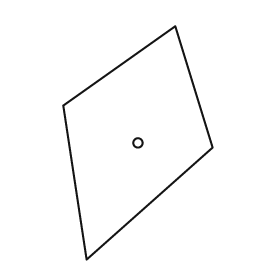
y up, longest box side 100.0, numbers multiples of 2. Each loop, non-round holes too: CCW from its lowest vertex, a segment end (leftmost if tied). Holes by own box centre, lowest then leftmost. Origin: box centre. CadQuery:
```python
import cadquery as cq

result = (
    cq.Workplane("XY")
    .moveTo(-22.0, -50.0)
    .lineTo(32.0, -2.0)
    .lineTo(16.0, 50.0)
    .lineTo(-32.0, 16.0)
    .close()
    .moveTo(0.0, 0.0)
    .circle(2.0)
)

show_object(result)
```